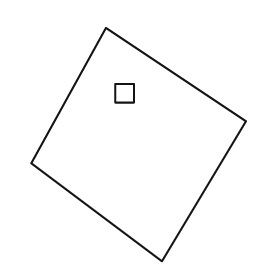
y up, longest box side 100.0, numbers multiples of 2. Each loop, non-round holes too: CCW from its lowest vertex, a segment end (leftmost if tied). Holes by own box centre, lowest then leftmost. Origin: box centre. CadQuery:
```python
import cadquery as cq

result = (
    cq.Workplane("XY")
    .moveTo(10.0, -50.0)
    .lineTo(46.0, 10.0)
    .lineTo(-14.0, 50.0)
    .lineTo(-46.0, -8.0)
    .close()
    .moveTo(-10.0, 18.0)
    .lineTo(-2.0, 18.0)
    .lineTo(-2.0, 26.0)
    .lineTo(-10.0, 26.0)
    .close()
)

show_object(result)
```